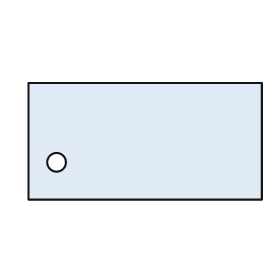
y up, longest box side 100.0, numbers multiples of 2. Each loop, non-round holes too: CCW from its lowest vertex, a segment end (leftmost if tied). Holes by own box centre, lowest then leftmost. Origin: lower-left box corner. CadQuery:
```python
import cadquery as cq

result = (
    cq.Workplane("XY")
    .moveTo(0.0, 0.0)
    .lineTo(100.0, 0.0)
    .lineTo(100.0, 50.0)
    .lineTo(0.0, 50.0)
    .close()
    .moveTo(12.0, 16.0)
    .circle(4.0)
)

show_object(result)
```